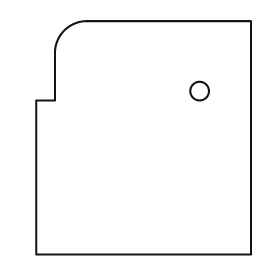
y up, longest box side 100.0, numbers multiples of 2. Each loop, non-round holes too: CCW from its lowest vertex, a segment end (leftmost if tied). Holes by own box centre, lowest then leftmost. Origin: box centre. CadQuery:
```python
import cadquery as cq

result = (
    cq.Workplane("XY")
    .moveTo(-46.0, -50.0)
    .lineTo(46.0, -50.0)
    .lineTo(46.0, 50.0)
    .lineTo(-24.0, 50.0)
    .threePointArc((-34.0, 46.0), (-38.0, 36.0))
    .lineTo(-38.0, 16.0)
    .lineTo(-46.0, 16.0)
    .close()
    .moveTo(24.0, 20.0)
    .circle(4.0)
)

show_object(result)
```